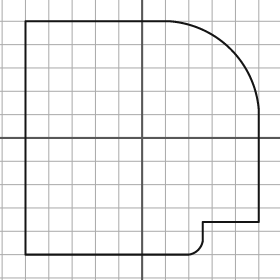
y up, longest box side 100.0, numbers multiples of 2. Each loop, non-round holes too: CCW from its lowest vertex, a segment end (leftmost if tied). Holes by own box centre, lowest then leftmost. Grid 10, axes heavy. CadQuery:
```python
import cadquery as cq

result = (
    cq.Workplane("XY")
    .moveTo(-50.0, -50.0)
    .lineTo(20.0, -50.0)
    .threePointArc((24.0, -48.0), (26.0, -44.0))
    .lineTo(26.0, -36.0)
    .lineTo(50.0, -36.0)
    .lineTo(50.0, 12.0)
    .threePointArc((38.0, 38.0), (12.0, 50.0))
    .lineTo(-50.0, 50.0)
    .close()
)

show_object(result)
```